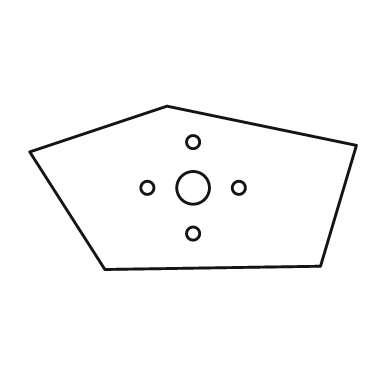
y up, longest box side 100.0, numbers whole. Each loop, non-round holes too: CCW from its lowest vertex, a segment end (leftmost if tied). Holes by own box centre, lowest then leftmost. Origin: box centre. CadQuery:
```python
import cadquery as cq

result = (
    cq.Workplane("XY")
    .moveTo(-27.0, -25.0)
    .lineTo(39.0, -24.0)
    .lineTo(50.0, 13.0)
    .lineTo(-8.0, 25.0)
    .lineTo(-50.0, 11.0)
    .close()
    .moveTo(0.0, -14.0)
    .circle(2.0)
    .moveTo(-14.0, 0.0)
    .circle(2.0)
    .moveTo(0.0, 0.0)
    .circle(5.0)
    .moveTo(14.0, 0.0)
    .circle(2.0)
    .moveTo(0.0, 14.0)
    .circle(2.0)
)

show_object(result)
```